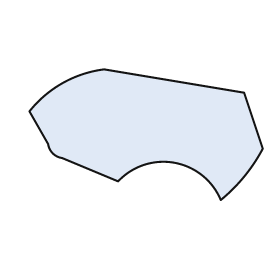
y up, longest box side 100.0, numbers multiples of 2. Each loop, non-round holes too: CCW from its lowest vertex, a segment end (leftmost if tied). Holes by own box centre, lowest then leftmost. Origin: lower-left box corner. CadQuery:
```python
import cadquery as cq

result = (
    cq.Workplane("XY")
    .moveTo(82.0, 0.0)
    .threePointArc((92.0, 10.0), (100.0, 22.0))
    .lineTo(92.0, 46.0)
    .lineTo(32.0, 56.0)
    .threePointArc((14.0, 50.0), (0.0, 38.0))
    .lineTo(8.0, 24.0)
    .threePointArc((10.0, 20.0), (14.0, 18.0))
    .lineTo(38.0, 8.0)
    .threePointArc((62.0, 16.0), (82.0, 0.0))
    .close()
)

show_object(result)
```